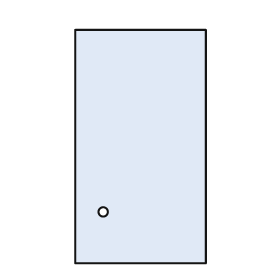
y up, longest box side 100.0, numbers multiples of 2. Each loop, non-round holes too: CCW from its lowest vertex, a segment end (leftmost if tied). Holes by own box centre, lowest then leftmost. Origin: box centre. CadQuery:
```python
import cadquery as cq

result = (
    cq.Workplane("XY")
    .moveTo(-28.0, -50.0)
    .lineTo(28.0, -50.0)
    .lineTo(28.0, 50.0)
    .lineTo(-28.0, 50.0)
    .close()
    .moveTo(-16.0, -28.0)
    .circle(2.0)
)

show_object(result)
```